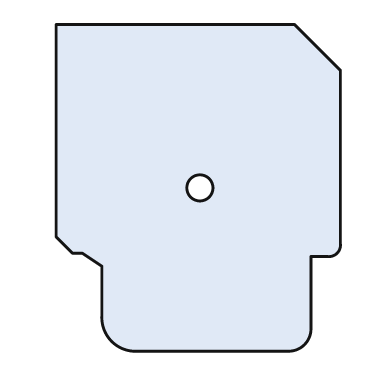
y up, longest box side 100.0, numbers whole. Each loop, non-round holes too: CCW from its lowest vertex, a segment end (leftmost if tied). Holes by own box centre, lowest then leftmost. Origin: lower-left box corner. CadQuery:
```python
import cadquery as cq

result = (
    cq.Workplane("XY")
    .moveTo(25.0, 0.0)
    .lineTo(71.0, 0.0)
    .threePointArc((76.0, 2.0), (78.0, 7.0))
    .lineTo(78.0, 29.0)
    .lineTo(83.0, 29.0)
    .threePointArc((86.0, 30.0), (87.0, 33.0))
    .lineTo(87.0, 86.0)
    .lineTo(73.0, 100.0)
    .lineTo(0.0, 100.0)
    .lineTo(0.0, 35.0)
    .lineTo(5.0, 30.0)
    .lineTo(8.0, 30.0)
    .lineTo(14.0, 26.0)
    .lineTo(14.0, 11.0)
    .threePointArc((17.0, 3.0), (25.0, 0.0))
    .close()
    .moveTo(44.0, 50.0)
    .circle(4.0)
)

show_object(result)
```